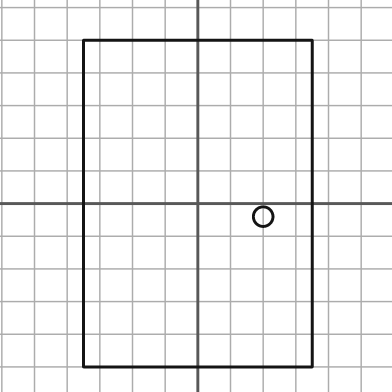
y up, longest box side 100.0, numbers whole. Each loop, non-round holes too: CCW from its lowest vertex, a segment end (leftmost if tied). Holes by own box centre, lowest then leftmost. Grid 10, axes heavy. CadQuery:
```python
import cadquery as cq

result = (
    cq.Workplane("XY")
    .moveTo(-35.0, -50.0)
    .lineTo(35.0, -50.0)
    .lineTo(35.0, 50.0)
    .lineTo(-35.0, 50.0)
    .close()
    .moveTo(20.0, -4.0)
    .circle(3.0)
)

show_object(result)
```